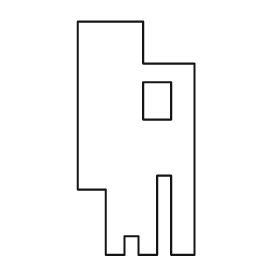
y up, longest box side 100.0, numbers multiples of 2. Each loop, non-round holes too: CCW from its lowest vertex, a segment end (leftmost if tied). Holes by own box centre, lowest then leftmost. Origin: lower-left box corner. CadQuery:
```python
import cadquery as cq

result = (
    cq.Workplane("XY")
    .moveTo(12.0, 0.0)
    .lineTo(20.0, 0.0)
    .lineTo(20.0, 8.0)
    .lineTo(26.0, 8.0)
    .lineTo(26.0, 0.0)
    .lineTo(34.0, 0.0)
    .lineTo(34.0, 34.0)
    .lineTo(40.0, 34.0)
    .lineTo(40.0, 0.0)
    .lineTo(50.0, 0.0)
    .lineTo(50.0, 82.0)
    .lineTo(28.0, 82.0)
    .lineTo(28.0, 100.0)
    .lineTo(0.0, 100.0)
    .lineTo(0.0, 28.0)
    .lineTo(12.0, 28.0)
    .close()
    .moveTo(28.0, 58.0)
    .lineTo(40.0, 58.0)
    .lineTo(40.0, 74.0)
    .lineTo(28.0, 74.0)
    .close()
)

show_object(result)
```